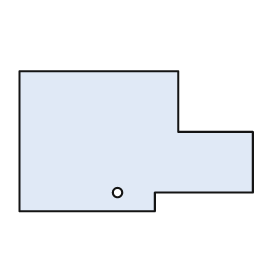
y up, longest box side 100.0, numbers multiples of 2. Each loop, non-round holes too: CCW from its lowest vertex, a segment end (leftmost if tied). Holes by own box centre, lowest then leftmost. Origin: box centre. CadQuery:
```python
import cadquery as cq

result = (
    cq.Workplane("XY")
    .moveTo(-50.0, -30.0)
    .lineTo(8.0, -30.0)
    .lineTo(8.0, -22.0)
    .lineTo(50.0, -22.0)
    .lineTo(50.0, 4.0)
    .lineTo(18.0, 4.0)
    .lineTo(18.0, 30.0)
    .lineTo(-50.0, 30.0)
    .close()
    .moveTo(-8.0, -22.0)
    .circle(2.0)
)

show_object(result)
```